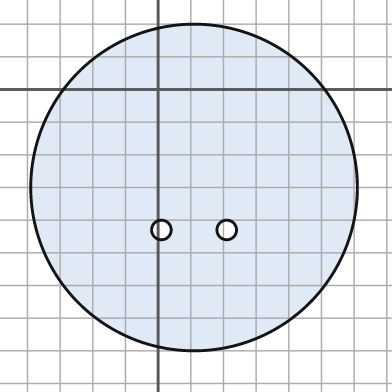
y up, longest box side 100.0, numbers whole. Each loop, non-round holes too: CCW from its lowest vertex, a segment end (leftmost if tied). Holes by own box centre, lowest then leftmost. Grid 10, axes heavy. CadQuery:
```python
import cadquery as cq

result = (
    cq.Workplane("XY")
    .moveTo(11.0, -30.0)
    .circle(50.0)
    .moveTo(1.0, -43.0)
    .circle(3.0)
    .moveTo(21.0, -43.0)
    .circle(3.0)
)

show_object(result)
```